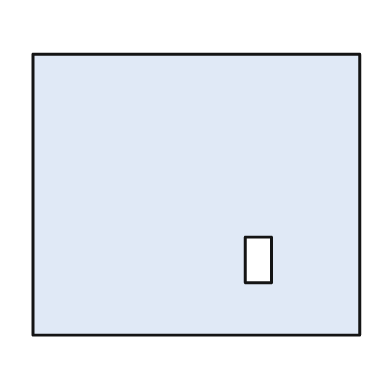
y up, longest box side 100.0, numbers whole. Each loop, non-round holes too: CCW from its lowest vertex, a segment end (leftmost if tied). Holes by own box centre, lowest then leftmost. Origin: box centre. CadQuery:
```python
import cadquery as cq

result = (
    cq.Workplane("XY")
    .moveTo(-50.0, -43.0)
    .lineTo(50.0, -43.0)
    .lineTo(50.0, 43.0)
    .lineTo(-50.0, 43.0)
    .close()
    .moveTo(15.0, -27.0)
    .lineTo(23.0, -27.0)
    .lineTo(23.0, -13.0)
    .lineTo(15.0, -13.0)
    .close()
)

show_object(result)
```